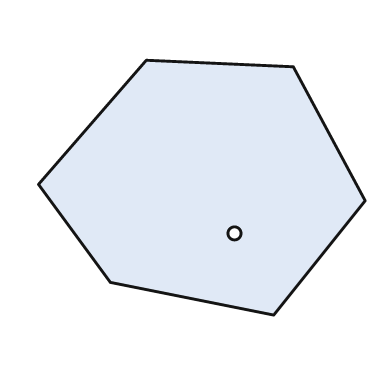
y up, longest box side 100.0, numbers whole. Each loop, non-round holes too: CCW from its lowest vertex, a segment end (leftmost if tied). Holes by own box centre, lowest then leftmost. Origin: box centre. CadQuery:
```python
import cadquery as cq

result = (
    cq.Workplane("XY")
    .moveTo(22.0, -39.0)
    .lineTo(50.0, -4.0)
    .lineTo(28.0, 37.0)
    .lineTo(-17.0, 39.0)
    .lineTo(-50.0, 1.0)
    .lineTo(-28.0, -29.0)
    .close()
    .moveTo(10.0, -14.0)
    .circle(2.0)
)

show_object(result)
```